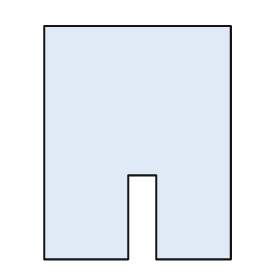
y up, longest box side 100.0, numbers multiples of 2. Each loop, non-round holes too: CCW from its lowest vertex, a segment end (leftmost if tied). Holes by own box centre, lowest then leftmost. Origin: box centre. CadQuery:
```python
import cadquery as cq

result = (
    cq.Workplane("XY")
    .moveTo(-40.0, -50.0)
    .lineTo(-4.0, -50.0)
    .lineTo(-4.0, -14.0)
    .lineTo(8.0, -14.0)
    .lineTo(8.0, -50.0)
    .lineTo(40.0, -50.0)
    .lineTo(40.0, 50.0)
    .lineTo(-40.0, 50.0)
    .close()
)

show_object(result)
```